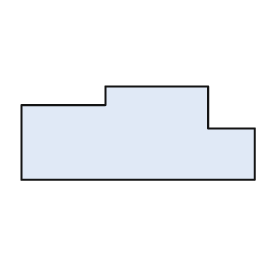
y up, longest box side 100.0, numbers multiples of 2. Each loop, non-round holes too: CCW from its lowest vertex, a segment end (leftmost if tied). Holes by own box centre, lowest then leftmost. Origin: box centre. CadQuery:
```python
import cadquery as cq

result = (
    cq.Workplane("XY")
    .moveTo(-50.0, -20.0)
    .lineTo(50.0, -20.0)
    .lineTo(50.0, 2.0)
    .lineTo(30.0, 2.0)
    .lineTo(30.0, 20.0)
    .lineTo(-14.0, 20.0)
    .lineTo(-14.0, 12.0)
    .lineTo(-50.0, 12.0)
    .close()
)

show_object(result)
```